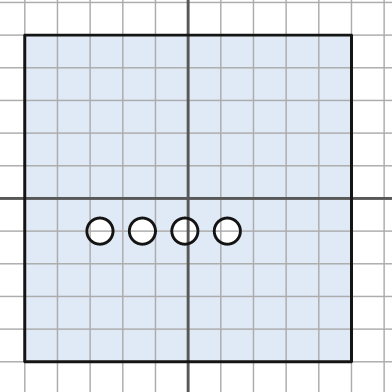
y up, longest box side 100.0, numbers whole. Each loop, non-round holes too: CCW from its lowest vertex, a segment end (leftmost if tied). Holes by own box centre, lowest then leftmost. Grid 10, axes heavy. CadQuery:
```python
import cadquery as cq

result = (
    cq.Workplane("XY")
    .moveTo(-50.0, -50.0)
    .lineTo(50.0, -50.0)
    .lineTo(50.0, 50.0)
    .lineTo(-50.0, 50.0)
    .close()
    .moveTo(-27.0, -10.0)
    .circle(4.0)
    .moveTo(-14.0, -10.0)
    .circle(4.0)
    .moveTo(-1.0, -10.0)
    .circle(4.0)
    .moveTo(12.0, -10.0)
    .circle(4.0)
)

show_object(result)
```